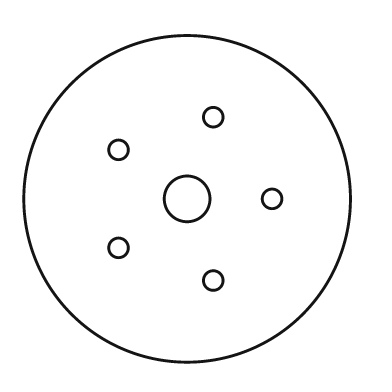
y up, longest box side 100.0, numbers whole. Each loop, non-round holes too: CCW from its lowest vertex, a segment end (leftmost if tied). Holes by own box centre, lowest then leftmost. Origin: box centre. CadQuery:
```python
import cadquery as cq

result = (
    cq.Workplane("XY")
    .moveTo(0.0, 0.0)
    .circle(50.0)
    .moveTo(8.0, -25.0)
    .circle(3.0)
    .moveTo(-21.0, -15.0)
    .circle(3.0)
    .moveTo(0.0, 0.0)
    .circle(7.0)
    .moveTo(26.0, 0.0)
    .circle(3.0)
    .moveTo(-21.0, 15.0)
    .circle(3.0)
    .moveTo(8.0, 25.0)
    .circle(3.0)
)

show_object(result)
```